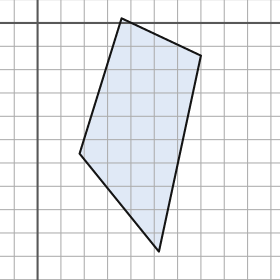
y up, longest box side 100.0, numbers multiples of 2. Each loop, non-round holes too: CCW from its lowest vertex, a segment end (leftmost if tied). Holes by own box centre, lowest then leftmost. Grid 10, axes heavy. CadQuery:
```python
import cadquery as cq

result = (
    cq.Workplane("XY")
    .moveTo(52.0, -98.0)
    .lineTo(70.0, -14.0)
    .lineTo(36.0, 2.0)
    .lineTo(18.0, -56.0)
    .close()
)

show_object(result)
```